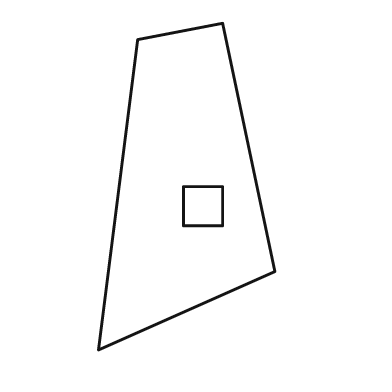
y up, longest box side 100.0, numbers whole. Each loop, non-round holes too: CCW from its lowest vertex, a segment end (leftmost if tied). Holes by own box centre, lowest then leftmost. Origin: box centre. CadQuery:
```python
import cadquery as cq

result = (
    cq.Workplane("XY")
    .moveTo(-27.0, -50.0)
    .lineTo(27.0, -26.0)
    .lineTo(11.0, 50.0)
    .lineTo(-15.0, 45.0)
    .close()
    .moveTo(-1.0, -12.0)
    .lineTo(11.0, -12.0)
    .lineTo(11.0, 0.0)
    .lineTo(-1.0, 0.0)
    .close()
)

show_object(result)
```